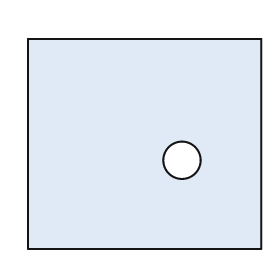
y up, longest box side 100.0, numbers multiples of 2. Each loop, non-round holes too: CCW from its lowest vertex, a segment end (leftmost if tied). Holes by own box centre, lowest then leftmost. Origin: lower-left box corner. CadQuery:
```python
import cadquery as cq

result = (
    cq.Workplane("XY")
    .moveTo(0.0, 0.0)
    .lineTo(100.0, 0.0)
    .lineTo(100.0, 90.0)
    .lineTo(0.0, 90.0)
    .close()
    .moveTo(66.0, 38.0)
    .circle(8.0)
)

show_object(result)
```